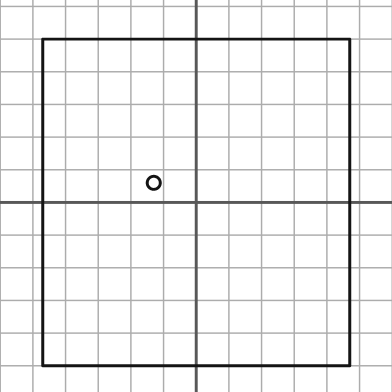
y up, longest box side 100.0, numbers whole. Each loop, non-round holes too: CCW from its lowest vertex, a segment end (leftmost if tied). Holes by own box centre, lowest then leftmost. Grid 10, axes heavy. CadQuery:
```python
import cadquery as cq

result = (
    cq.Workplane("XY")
    .moveTo(-47.0, -50.0)
    .lineTo(47.0, -50.0)
    .lineTo(47.0, 50.0)
    .lineTo(-47.0, 50.0)
    .close()
    .moveTo(-13.0, 6.0)
    .circle(2.0)
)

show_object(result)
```